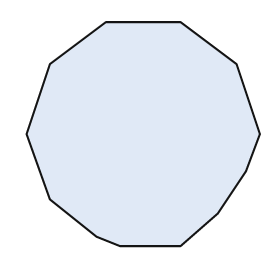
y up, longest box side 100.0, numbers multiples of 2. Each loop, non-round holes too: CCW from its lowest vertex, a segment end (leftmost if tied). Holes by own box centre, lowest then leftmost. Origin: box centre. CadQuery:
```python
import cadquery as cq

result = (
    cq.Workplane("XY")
    .moveTo(-10.0, -48.0)
    .lineTo(16.0, -48.0)
    .lineTo(32.0, -34.0)
    .lineTo(44.0, -16.0)
    .lineTo(50.0, 0.0)
    .lineTo(40.0, 30.0)
    .lineTo(16.0, 48.0)
    .lineTo(-16.0, 48.0)
    .lineTo(-40.0, 30.0)
    .lineTo(-50.0, 0.0)
    .lineTo(-40.0, -28.0)
    .lineTo(-20.0, -44.0)
    .close()
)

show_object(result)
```